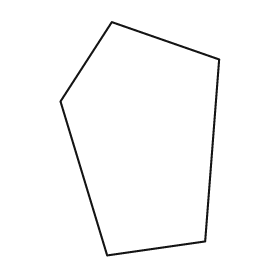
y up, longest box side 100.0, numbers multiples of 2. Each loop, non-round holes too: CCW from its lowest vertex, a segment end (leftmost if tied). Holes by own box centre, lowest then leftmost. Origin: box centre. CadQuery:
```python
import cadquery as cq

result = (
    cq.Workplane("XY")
    .moveTo(-14.0, -50.0)
    .lineTo(28.0, -44.0)
    .lineTo(34.0, 34.0)
    .lineTo(-12.0, 50.0)
    .lineTo(-34.0, 16.0)
    .close()
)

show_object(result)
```